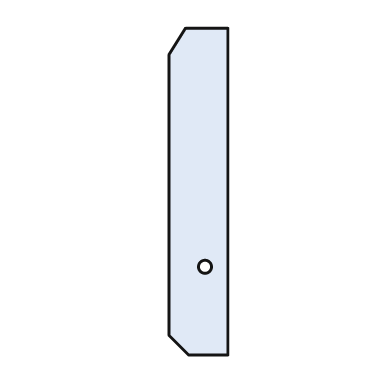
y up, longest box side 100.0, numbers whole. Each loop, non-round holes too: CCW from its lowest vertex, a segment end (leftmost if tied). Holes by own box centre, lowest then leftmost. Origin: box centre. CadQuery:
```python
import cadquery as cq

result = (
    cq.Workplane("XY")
    .moveTo(-3.0, -50.0)
    .lineTo(9.0, -50.0)
    .lineTo(9.0, 50.0)
    .lineTo(-4.0, 50.0)
    .lineTo(-9.0, 42.0)
    .lineTo(-9.0, -44.0)
    .close()
    .moveTo(2.0, -23.0)
    .circle(2.0)
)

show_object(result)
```